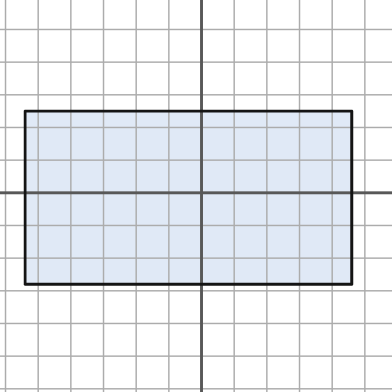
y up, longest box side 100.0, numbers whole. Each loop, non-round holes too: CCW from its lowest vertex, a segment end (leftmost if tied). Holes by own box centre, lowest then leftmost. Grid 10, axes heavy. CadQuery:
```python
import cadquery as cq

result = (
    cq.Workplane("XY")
    .moveTo(-54.0, -28.0)
    .lineTo(46.0, -28.0)
    .lineTo(46.0, 25.0)
    .lineTo(-54.0, 25.0)
    .close()
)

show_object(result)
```